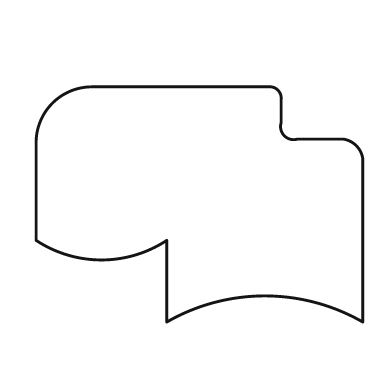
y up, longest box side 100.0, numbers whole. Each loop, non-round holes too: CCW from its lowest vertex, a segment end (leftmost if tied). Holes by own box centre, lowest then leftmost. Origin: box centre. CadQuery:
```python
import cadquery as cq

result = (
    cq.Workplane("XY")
    .moveTo(-10.0, -36.0)
    .threePointArc((20.0, -28.0), (50.0, -36.0))
    .lineTo(50.0, 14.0)
    .threePointArc((48.0, 18.0), (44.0, 20.0))
    .lineTo(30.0, 20.0)
    .threePointArc((26.0, 21.0), (25.0, 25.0))
    .lineTo(25.0, 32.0)
    .threePointArc((24.0, 35.0), (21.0, 36.0))
    .lineTo(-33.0, 36.0)
    .threePointArc((-45.0, 31.0), (-50.0, 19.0))
    .lineTo(-50.0, -11.0)
    .threePointArc((-30.0, -17.0), (-10.0, -11.0))
    .close()
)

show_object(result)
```